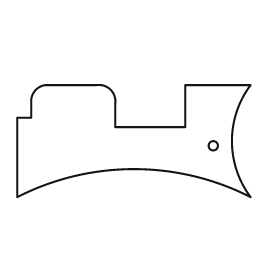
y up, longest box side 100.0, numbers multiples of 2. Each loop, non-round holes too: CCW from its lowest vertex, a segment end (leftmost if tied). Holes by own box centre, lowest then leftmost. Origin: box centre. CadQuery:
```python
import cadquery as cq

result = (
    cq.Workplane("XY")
    .moveTo(-50.0, -24.0)
    .threePointArc((0.0, -12.0), (50.0, -24.0))
    .threePointArc((42.0, 0.0), (50.0, 24.0))
    .lineTo(22.0, 24.0)
    .lineTo(22.0, 6.0)
    .lineTo(-8.0, 6.0)
    .lineTo(-8.0, 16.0)
    .threePointArc((-10.0, 22.0), (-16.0, 24.0))
    .lineTo(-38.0, 24.0)
    .threePointArc((-42.0, 22.0), (-44.0, 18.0))
    .lineTo(-44.0, 10.0)
    .lineTo(-50.0, 10.0)
    .close()
    .moveTo(34.0, -2.0)
    .circle(2.0)
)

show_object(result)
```